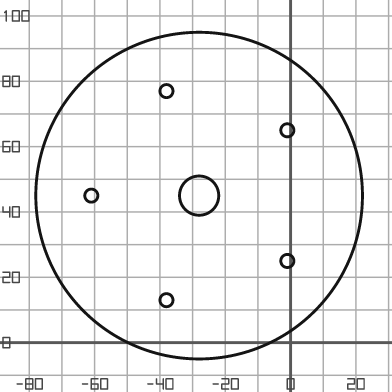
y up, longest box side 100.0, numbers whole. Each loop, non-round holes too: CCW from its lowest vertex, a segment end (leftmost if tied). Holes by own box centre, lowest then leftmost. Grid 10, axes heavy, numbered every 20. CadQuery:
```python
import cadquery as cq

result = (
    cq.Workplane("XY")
    .moveTo(-28.0, 45.0)
    .circle(50.0)
    .moveTo(-38.0, 13.0)
    .circle(2.0)
    .moveTo(-1.0, 25.0)
    .circle(2.0)
    .moveTo(-61.0, 45.0)
    .circle(2.0)
    .moveTo(-28.0, 45.0)
    .circle(6.0)
    .moveTo(-1.0, 65.0)
    .circle(2.0)
    .moveTo(-38.0, 77.0)
    .circle(2.0)
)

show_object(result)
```